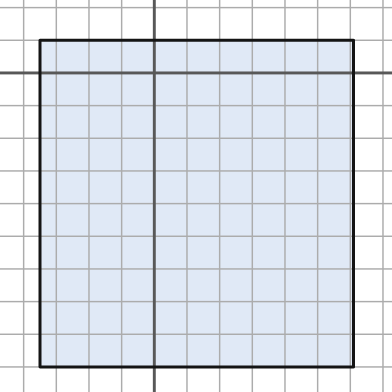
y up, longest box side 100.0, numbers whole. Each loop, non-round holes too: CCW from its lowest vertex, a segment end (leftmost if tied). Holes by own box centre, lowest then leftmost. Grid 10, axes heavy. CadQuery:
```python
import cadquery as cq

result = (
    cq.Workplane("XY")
    .moveTo(-35.0, -90.0)
    .lineTo(61.0, -90.0)
    .lineTo(61.0, 10.0)
    .lineTo(-35.0, 10.0)
    .close()
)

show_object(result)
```